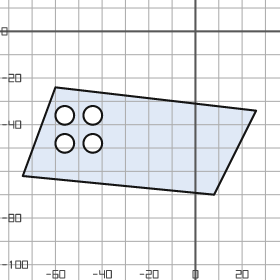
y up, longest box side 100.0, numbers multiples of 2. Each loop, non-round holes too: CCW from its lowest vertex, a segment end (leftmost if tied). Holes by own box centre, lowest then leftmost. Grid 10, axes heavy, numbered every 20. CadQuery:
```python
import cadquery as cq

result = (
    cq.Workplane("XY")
    .moveTo(8.0, -70.0)
    .lineTo(26.0, -34.0)
    .lineTo(-60.0, -24.0)
    .lineTo(-74.0, -62.0)
    .close()
    .moveTo(-56.0, -48.0)
    .circle(4.0)
    .moveTo(-44.0, -48.0)
    .circle(4.0)
    .moveTo(-56.0, -36.0)
    .circle(4.0)
    .moveTo(-44.0, -36.0)
    .circle(4.0)
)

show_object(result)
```